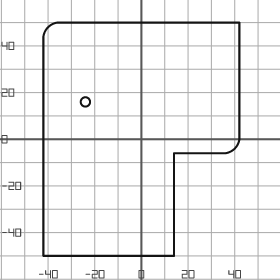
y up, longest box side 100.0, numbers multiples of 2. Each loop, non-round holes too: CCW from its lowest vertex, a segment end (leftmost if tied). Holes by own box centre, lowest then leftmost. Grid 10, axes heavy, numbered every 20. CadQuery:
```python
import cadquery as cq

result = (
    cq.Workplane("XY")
    .moveTo(-42.0, -50.0)
    .lineTo(14.0, -50.0)
    .lineTo(14.0, -6.0)
    .lineTo(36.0, -6.0)
    .threePointArc((40.0, -4.0), (42.0, 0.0))
    .lineTo(42.0, 50.0)
    .lineTo(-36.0, 50.0)
    .threePointArc((-40.0, 48.0), (-42.0, 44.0))
    .close()
    .moveTo(-24.0, 16.0)
    .circle(2.0)
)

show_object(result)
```